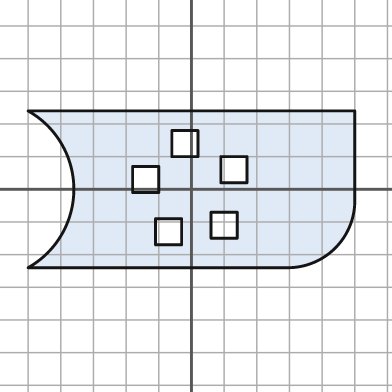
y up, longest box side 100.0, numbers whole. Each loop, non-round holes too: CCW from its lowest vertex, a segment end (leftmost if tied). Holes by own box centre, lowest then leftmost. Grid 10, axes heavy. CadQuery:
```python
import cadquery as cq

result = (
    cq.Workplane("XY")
    .moveTo(-50.0, -24.0)
    .lineTo(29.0, -24.0)
    .threePointArc((44.0, -18.0), (50.0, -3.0))
    .lineTo(50.0, 24.0)
    .lineTo(-50.0, 24.0)
    .threePointArc((-36.0, 0.0), (-50.0, -24.0))
    .close()
    .moveTo(-11.0, -17.0)
    .lineTo(-3.0, -17.0)
    .lineTo(-3.0, -9.0)
    .lineTo(-11.0, -9.0)
    .close()
    .moveTo(6.0, -15.0)
    .lineTo(14.0, -15.0)
    .lineTo(14.0, -7.0)
    .lineTo(6.0, -7.0)
    .close()
    .moveTo(-18.0, -1.0)
    .lineTo(-10.0, -1.0)
    .lineTo(-10.0, 7.0)
    .lineTo(-18.0, 7.0)
    .close()
    .moveTo(9.0, 2.0)
    .lineTo(17.0, 2.0)
    .lineTo(17.0, 10.0)
    .lineTo(9.0, 10.0)
    .close()
    .moveTo(-6.0, 10.0)
    .lineTo(2.0, 10.0)
    .lineTo(2.0, 18.0)
    .lineTo(-6.0, 18.0)
    .close()
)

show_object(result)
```